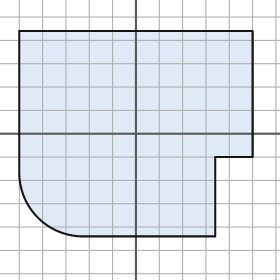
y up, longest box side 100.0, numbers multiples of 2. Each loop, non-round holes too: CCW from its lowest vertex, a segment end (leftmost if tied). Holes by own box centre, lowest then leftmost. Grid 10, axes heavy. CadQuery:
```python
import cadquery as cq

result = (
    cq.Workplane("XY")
    .moveTo(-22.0, -44.0)
    .lineTo(34.0, -44.0)
    .lineTo(34.0, -10.0)
    .lineTo(50.0, -10.0)
    .lineTo(50.0, 44.0)
    .lineTo(-50.0, 44.0)
    .lineTo(-50.0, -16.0)
    .threePointArc((-42.0, -36.0), (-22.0, -44.0))
    .close()
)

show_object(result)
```